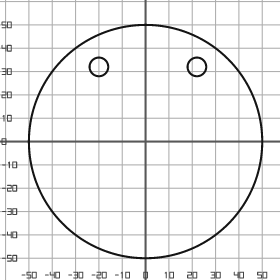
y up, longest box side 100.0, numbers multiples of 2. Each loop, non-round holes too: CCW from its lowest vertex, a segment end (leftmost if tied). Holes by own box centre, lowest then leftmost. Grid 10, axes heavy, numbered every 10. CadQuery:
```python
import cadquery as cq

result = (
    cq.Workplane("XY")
    .moveTo(0.0, 0.0)
    .circle(50.0)
    .moveTo(-20.0, 32.0)
    .circle(4.0)
    .moveTo(22.0, 32.0)
    .circle(4.0)
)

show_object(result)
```